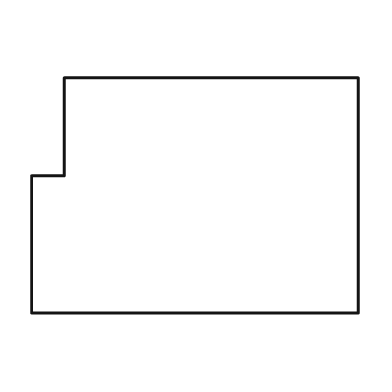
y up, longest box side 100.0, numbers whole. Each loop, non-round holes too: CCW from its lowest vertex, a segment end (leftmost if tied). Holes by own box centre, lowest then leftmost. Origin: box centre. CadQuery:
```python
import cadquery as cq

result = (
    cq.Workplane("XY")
    .moveTo(-50.0, -36.0)
    .lineTo(50.0, -36.0)
    .lineTo(50.0, 36.0)
    .lineTo(-40.0, 36.0)
    .lineTo(-40.0, 6.0)
    .lineTo(-50.0, 6.0)
    .close()
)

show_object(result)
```